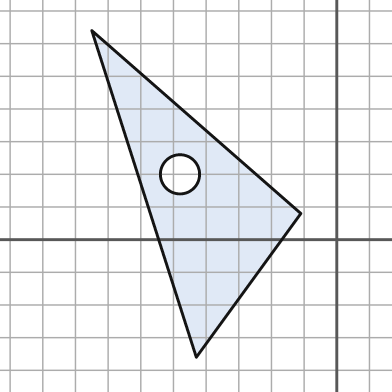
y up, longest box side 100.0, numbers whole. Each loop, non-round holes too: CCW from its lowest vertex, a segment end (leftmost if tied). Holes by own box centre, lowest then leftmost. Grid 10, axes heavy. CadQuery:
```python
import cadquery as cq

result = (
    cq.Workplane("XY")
    .moveTo(-43.0, -36.0)
    .lineTo(-11.0, 8.0)
    .lineTo(-75.0, 64.0)
    .close()
    .moveTo(-48.0, 20.0)
    .circle(6.0)
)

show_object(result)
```